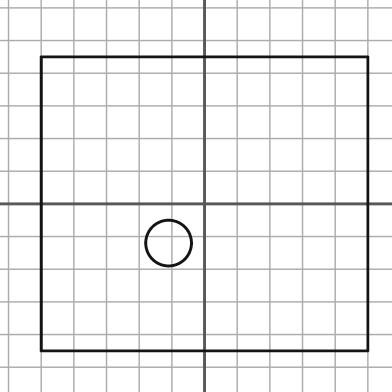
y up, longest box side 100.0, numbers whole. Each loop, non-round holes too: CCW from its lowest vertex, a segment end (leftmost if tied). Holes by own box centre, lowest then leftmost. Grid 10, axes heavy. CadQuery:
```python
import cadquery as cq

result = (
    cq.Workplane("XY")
    .moveTo(-50.0, -45.0)
    .lineTo(50.0, -45.0)
    .lineTo(50.0, 45.0)
    .lineTo(-50.0, 45.0)
    .close()
    .moveTo(-11.0, -12.0)
    .circle(7.0)
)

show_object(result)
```